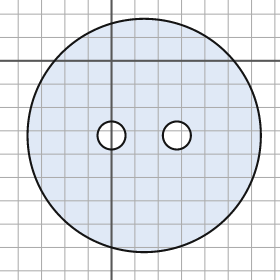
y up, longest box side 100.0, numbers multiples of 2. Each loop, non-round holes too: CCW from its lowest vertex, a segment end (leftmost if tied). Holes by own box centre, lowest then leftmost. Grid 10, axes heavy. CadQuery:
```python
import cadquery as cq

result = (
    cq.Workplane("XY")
    .moveTo(14.0, -32.0)
    .circle(50.0)
    .moveTo(0.0, -32.0)
    .circle(6.0)
    .moveTo(28.0, -32.0)
    .circle(6.0)
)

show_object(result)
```